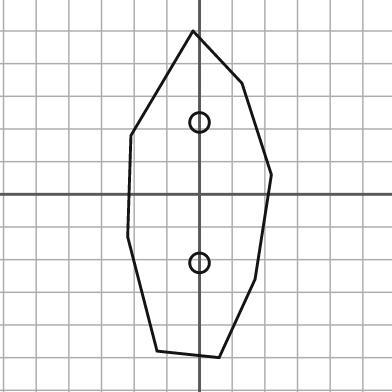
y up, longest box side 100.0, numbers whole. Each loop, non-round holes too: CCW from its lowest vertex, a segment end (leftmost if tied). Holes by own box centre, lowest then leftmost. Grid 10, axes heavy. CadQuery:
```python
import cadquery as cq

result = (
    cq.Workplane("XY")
    .moveTo(6.0, -50.0)
    .lineTo(17.0, -26.0)
    .lineTo(22.0, 6.0)
    .lineTo(13.0, 34.0)
    .lineTo(-2.0, 50.0)
    .lineTo(-21.0, 18.0)
    .lineTo(-22.0, -13.0)
    .lineTo(-13.0, -48.0)
    .close()
    .moveTo(0.0, -21.0)
    .circle(3.0)
    .moveTo(0.0, 22.0)
    .circle(3.0)
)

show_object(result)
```